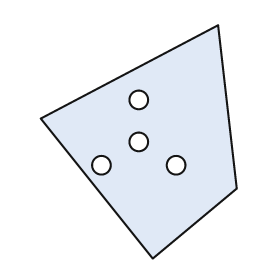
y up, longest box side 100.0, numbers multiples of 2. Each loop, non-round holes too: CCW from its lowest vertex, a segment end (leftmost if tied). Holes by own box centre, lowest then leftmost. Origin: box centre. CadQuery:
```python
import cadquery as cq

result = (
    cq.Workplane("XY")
    .moveTo(6.0, -50.0)
    .lineTo(42.0, -20.0)
    .lineTo(34.0, 50.0)
    .lineTo(-42.0, 10.0)
    .close()
    .moveTo(-16.0, -10.0)
    .circle(4.0)
    .moveTo(16.0, -10.0)
    .circle(4.0)
    .moveTo(0.0, 0.0)
    .circle(4.0)
    .moveTo(0.0, 18.0)
    .circle(4.0)
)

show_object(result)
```